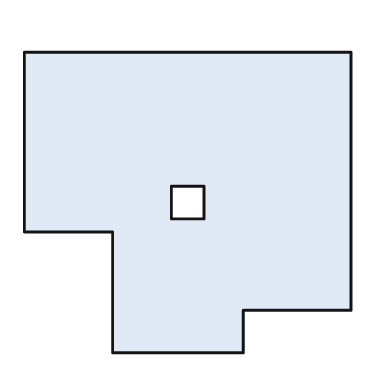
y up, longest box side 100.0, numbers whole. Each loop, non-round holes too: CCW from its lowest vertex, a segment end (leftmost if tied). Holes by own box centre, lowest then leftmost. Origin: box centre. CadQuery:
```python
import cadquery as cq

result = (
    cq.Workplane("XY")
    .moveTo(-23.0, -46.0)
    .lineTo(17.0, -46.0)
    .lineTo(17.0, -33.0)
    .lineTo(50.0, -33.0)
    .lineTo(50.0, 46.0)
    .lineTo(-50.0, 46.0)
    .lineTo(-50.0, -9.0)
    .lineTo(-23.0, -9.0)
    .close()
    .moveTo(-5.0, -5.0)
    .lineTo(5.0, -5.0)
    .lineTo(5.0, 5.0)
    .lineTo(-5.0, 5.0)
    .close()
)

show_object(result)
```